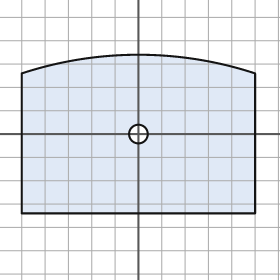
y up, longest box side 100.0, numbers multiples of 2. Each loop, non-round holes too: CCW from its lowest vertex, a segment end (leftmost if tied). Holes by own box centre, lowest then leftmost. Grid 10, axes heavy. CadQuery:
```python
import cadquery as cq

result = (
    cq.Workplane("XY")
    .moveTo(-50.0, -34.0)
    .lineTo(50.0, -34.0)
    .lineTo(50.0, 26.0)
    .threePointArc((0.0, 34.0), (-50.0, 26.0))
    .close()
    .moveTo(0.0, 0.0)
    .circle(4.0)
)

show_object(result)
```